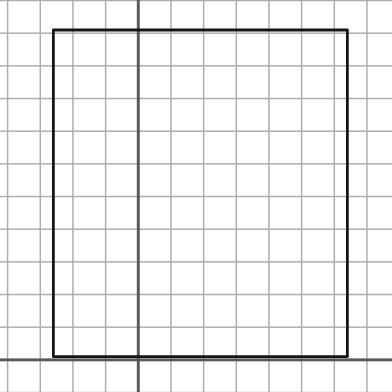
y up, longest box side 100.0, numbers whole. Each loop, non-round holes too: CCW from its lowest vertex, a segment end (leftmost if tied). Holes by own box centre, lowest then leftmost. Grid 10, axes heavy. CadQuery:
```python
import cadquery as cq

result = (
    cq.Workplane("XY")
    .moveTo(-26.0, 1.0)
    .lineTo(64.0, 1.0)
    .lineTo(64.0, 101.0)
    .lineTo(-26.0, 101.0)
    .close()
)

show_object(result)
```